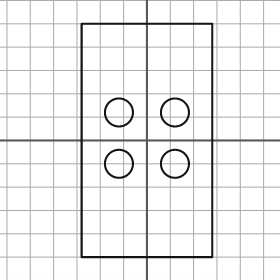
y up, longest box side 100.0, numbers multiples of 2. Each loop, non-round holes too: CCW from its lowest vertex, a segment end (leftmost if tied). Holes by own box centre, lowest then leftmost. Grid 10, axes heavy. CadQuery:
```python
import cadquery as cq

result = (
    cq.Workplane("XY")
    .moveTo(-28.0, -50.0)
    .lineTo(28.0, -50.0)
    .lineTo(28.0, 50.0)
    .lineTo(-28.0, 50.0)
    .close()
    .moveTo(-12.0, -10.0)
    .circle(6.0)
    .moveTo(12.0, -10.0)
    .circle(6.0)
    .moveTo(-12.0, 12.0)
    .circle(6.0)
    .moveTo(12.0, 12.0)
    .circle(6.0)
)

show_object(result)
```